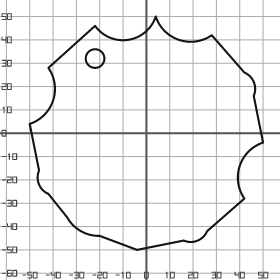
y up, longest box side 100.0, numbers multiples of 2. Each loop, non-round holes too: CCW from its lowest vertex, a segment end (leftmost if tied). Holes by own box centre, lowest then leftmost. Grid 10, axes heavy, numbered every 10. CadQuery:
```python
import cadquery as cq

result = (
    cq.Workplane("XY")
    .moveTo(-4.0, -50.0)
    .lineTo(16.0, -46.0)
    .threePointArc((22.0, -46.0), (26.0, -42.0))
    .lineTo(42.0, -28.0)
    .threePointArc((40.0, -14.0), (50.0, -4.0))
    .lineTo(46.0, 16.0)
    .threePointArc((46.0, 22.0), (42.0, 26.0))
    .lineTo(28.0, 42.0)
    .threePointArc((14.0, 40.0), (4.0, 50.0))
    .threePointArc((-8.0, 40.0), (-22.0, 46.0))
    .lineTo(-42.0, 28.0)
    .threePointArc((-40.0, 14.0), (-50.0, 4.0))
    .lineTo(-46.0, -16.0)
    .threePointArc((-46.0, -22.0), (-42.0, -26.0))
    .lineTo(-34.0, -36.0)
    .threePointArc((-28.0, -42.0), (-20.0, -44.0))
    .close()
    .moveTo(-22.0, 32.0)
    .circle(4.0)
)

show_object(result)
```